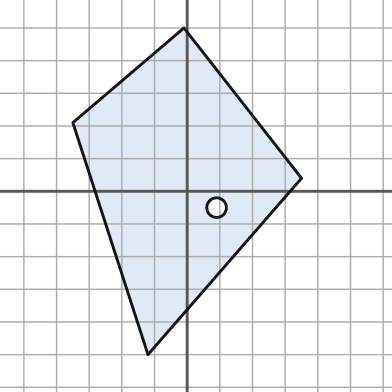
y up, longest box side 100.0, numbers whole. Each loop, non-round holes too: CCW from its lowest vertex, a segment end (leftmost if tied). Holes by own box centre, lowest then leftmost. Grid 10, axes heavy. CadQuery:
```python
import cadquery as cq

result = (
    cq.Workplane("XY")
    .moveTo(-12.0, -50.0)
    .lineTo(35.0, 4.0)
    .lineTo(-1.0, 50.0)
    .lineTo(-35.0, 21.0)
    .close()
    .moveTo(9.0, -5.0)
    .circle(3.0)
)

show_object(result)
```